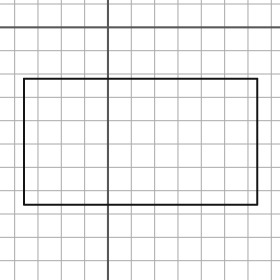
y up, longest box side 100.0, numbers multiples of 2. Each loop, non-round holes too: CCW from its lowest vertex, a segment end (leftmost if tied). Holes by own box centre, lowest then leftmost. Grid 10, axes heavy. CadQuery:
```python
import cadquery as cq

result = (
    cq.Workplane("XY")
    .moveTo(-36.0, -76.0)
    .lineTo(64.0, -76.0)
    .lineTo(64.0, -22.0)
    .lineTo(-36.0, -22.0)
    .close()
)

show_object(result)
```